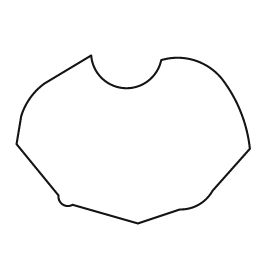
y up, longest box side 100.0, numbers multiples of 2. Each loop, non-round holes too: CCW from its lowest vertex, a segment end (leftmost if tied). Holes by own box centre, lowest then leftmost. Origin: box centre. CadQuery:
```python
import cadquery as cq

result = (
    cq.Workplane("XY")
    .moveTo(2.0, -36.0)
    .lineTo(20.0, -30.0)
    .threePointArc((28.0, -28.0), (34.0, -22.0))
    .lineTo(50.0, -4.0)
    .threePointArc((46.0, 12.0), (38.0, 26.0))
    .threePointArc((26.0, 34.0), (12.0, 34.0))
    .threePointArc((-4.0, 22.0), (-18.0, 36.0))
    .lineTo(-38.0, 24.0)
    .threePointArc((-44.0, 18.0), (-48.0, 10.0))
    .lineTo(-50.0, -2.0)
    .lineTo(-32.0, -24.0)
    .threePointArc((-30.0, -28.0), (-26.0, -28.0))
    .close()
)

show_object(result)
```